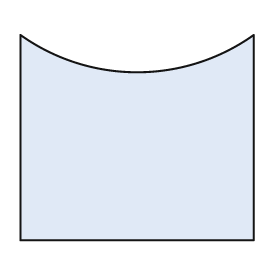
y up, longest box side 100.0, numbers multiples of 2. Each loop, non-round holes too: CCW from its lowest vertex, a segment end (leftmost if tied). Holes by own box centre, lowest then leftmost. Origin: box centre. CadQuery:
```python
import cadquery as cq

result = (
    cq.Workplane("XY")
    .moveTo(-50.0, -44.0)
    .lineTo(50.0, -44.0)
    .lineTo(50.0, 44.0)
    .threePointArc((0.0, 28.0), (-50.0, 44.0))
    .close()
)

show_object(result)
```